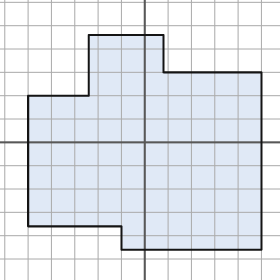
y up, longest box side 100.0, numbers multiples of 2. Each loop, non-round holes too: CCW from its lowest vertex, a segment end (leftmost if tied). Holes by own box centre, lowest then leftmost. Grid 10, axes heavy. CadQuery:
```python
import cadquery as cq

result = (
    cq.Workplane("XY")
    .moveTo(-10.0, -46.0)
    .lineTo(50.0, -46.0)
    .lineTo(50.0, 30.0)
    .lineTo(8.0, 30.0)
    .lineTo(8.0, 46.0)
    .lineTo(-24.0, 46.0)
    .lineTo(-24.0, 20.0)
    .lineTo(-50.0, 20.0)
    .lineTo(-50.0, -36.0)
    .lineTo(-10.0, -36.0)
    .close()
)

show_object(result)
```